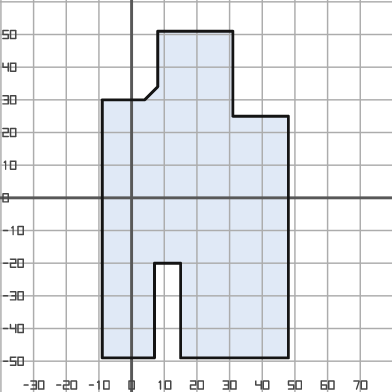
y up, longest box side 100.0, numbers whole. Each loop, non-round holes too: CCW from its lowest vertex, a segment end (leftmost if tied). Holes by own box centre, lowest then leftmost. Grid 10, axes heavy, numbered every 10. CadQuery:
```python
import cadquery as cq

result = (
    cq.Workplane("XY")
    .moveTo(-9.0, -49.0)
    .lineTo(7.0, -49.0)
    .lineTo(7.0, -20.0)
    .lineTo(15.0, -20.0)
    .lineTo(15.0, -49.0)
    .lineTo(48.0, -49.0)
    .lineTo(48.0, 25.0)
    .lineTo(31.0, 25.0)
    .lineTo(31.0, 51.0)
    .lineTo(8.0, 51.0)
    .lineTo(8.0, 34.0)
    .lineTo(4.0, 30.0)
    .lineTo(-9.0, 30.0)
    .close()
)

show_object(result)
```